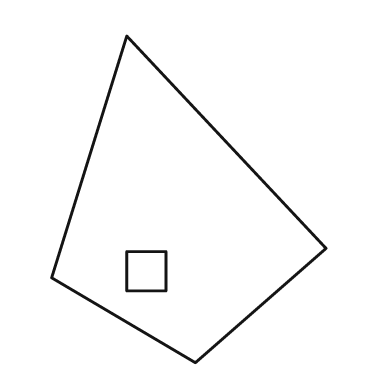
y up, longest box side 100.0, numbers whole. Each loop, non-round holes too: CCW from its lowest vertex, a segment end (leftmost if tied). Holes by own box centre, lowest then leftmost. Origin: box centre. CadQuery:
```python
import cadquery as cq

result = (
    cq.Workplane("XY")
    .moveTo(2.0, -50.0)
    .lineTo(42.0, -15.0)
    .lineTo(-19.0, 50.0)
    .lineTo(-42.0, -24.0)
    .close()
    .moveTo(-19.0, -28.0)
    .lineTo(-7.0, -28.0)
    .lineTo(-7.0, -16.0)
    .lineTo(-19.0, -16.0)
    .close()
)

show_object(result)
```